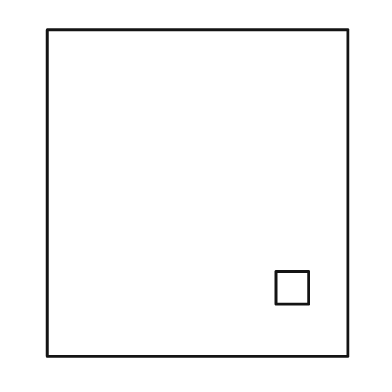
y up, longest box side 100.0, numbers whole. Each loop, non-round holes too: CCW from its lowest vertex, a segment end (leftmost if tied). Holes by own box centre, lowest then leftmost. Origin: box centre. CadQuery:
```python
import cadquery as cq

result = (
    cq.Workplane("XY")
    .moveTo(-46.0, -50.0)
    .lineTo(46.0, -50.0)
    .lineTo(46.0, 50.0)
    .lineTo(-46.0, 50.0)
    .close()
    .moveTo(24.0, -34.0)
    .lineTo(34.0, -34.0)
    .lineTo(34.0, -24.0)
    .lineTo(24.0, -24.0)
    .close()
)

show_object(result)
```